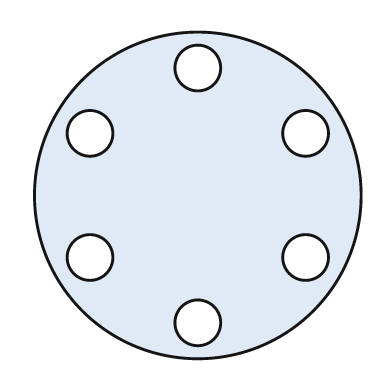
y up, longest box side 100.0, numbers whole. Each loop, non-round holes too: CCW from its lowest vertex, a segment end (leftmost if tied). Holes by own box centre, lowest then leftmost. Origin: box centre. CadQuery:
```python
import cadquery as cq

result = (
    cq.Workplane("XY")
    .moveTo(0.0, 0.0)
    .circle(50.0)
    .moveTo(0.0, -39.0)
    .circle(7.0)
    .moveTo(-33.0, -19.0)
    .circle(7.0)
    .moveTo(33.0, -19.0)
    .circle(7.0)
    .moveTo(-33.0, 19.0)
    .circle(7.0)
    .moveTo(33.0, 19.0)
    .circle(7.0)
    .moveTo(0.0, 39.0)
    .circle(7.0)
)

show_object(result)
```